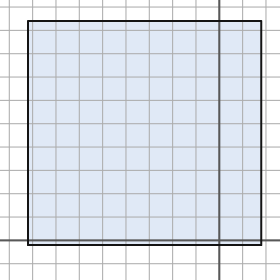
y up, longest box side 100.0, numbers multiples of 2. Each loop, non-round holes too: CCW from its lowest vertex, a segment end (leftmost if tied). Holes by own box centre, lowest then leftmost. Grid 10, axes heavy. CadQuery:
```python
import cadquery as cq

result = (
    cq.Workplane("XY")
    .moveTo(-82.0, -2.0)
    .lineTo(18.0, -2.0)
    .lineTo(18.0, 94.0)
    .lineTo(-82.0, 94.0)
    .close()
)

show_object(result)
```